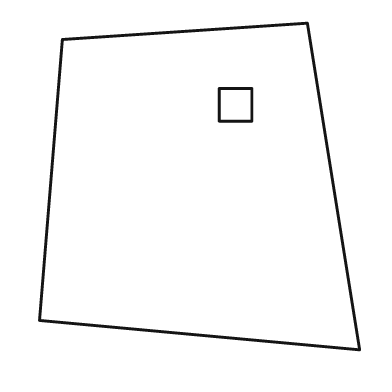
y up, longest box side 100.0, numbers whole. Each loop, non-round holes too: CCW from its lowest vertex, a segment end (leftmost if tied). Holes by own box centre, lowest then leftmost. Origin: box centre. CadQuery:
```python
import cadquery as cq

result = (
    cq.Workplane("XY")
    .moveTo(49.0, -50.0)
    .lineTo(33.0, 50.0)
    .lineTo(-42.0, 45.0)
    .lineTo(-49.0, -41.0)
    .close()
    .moveTo(6.0, 20.0)
    .lineTo(16.0, 20.0)
    .lineTo(16.0, 30.0)
    .lineTo(6.0, 30.0)
    .close()
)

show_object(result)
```